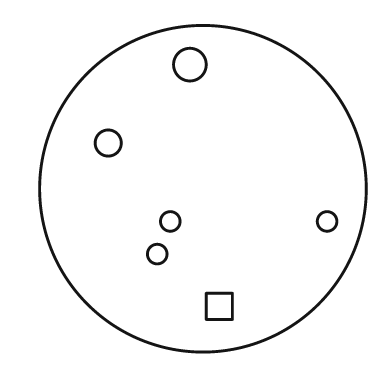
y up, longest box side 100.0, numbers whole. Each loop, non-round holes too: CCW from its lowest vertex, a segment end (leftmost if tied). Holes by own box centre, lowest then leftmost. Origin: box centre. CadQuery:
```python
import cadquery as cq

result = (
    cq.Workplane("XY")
    .moveTo(0.0, 0.0)
    .circle(50.0)
    .moveTo(1.0, -40.0)
    .lineTo(9.0, -40.0)
    .lineTo(9.0, -32.0)
    .lineTo(1.0, -32.0)
    .close()
    .moveTo(-14.0, -20.0)
    .circle(3.0)
    .moveTo(-10.0, -10.0)
    .circle(3.0)
    .moveTo(38.0, -10.0)
    .circle(3.0)
    .moveTo(-29.0, 14.0)
    .circle(4.0)
    .moveTo(-4.0, 38.0)
    .circle(5.0)
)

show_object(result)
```